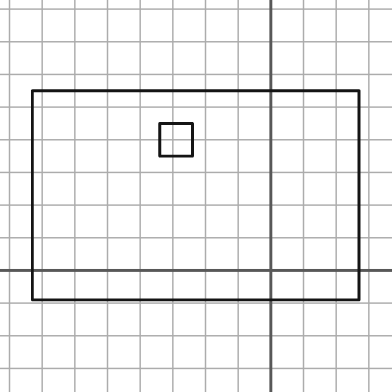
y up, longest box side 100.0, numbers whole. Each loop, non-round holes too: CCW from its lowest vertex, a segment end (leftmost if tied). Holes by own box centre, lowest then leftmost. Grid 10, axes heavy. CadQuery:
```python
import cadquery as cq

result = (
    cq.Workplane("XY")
    .moveTo(-73.0, -9.0)
    .lineTo(27.0, -9.0)
    .lineTo(27.0, 55.0)
    .lineTo(-73.0, 55.0)
    .close()
    .moveTo(-34.0, 35.0)
    .lineTo(-24.0, 35.0)
    .lineTo(-24.0, 45.0)
    .lineTo(-34.0, 45.0)
    .close()
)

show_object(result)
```